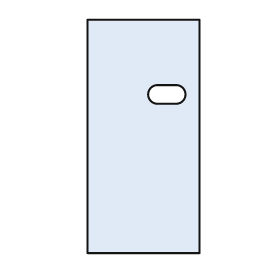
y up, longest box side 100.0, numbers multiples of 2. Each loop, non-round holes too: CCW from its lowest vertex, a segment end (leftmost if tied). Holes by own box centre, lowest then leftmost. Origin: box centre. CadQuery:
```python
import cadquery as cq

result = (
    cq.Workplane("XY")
    .moveTo(-24.0, -50.0)
    .lineTo(24.0, -50.0)
    .lineTo(24.0, 50.0)
    .lineTo(-24.0, 50.0)
    .close()
    .moveTo(6.0, 14.0)
    .lineTo(14.0, 14.0)
    .threePointArc((18.0, 18.0), (14.0, 22.0))
    .lineTo(6.0, 22.0)
    .threePointArc((2.0, 18.0), (6.0, 14.0))
    .close()
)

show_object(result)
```